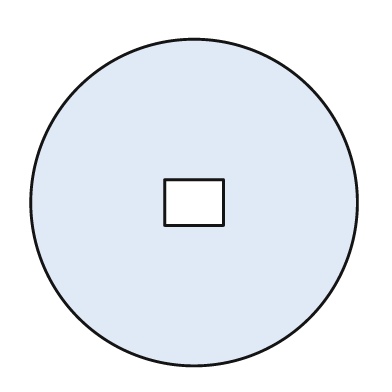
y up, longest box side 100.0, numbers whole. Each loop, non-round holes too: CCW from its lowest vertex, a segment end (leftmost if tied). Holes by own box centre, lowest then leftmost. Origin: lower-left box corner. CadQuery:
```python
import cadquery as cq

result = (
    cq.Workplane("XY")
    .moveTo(50.0, 50.0)
    .circle(50.0)
    .moveTo(41.0, 43.0)
    .lineTo(59.0, 43.0)
    .lineTo(59.0, 57.0)
    .lineTo(41.0, 57.0)
    .close()
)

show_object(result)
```